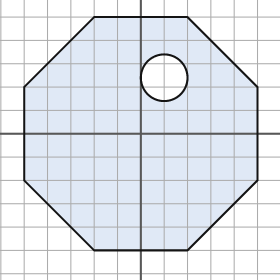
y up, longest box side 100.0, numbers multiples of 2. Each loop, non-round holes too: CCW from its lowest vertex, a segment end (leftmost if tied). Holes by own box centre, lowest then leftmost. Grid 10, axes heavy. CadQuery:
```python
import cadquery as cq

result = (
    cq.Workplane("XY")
    .moveTo(-20.0, -50.0)
    .lineTo(20.0, -50.0)
    .lineTo(50.0, -20.0)
    .lineTo(50.0, 20.0)
    .lineTo(20.0, 50.0)
    .lineTo(-20.0, 50.0)
    .lineTo(-50.0, 20.0)
    .lineTo(-50.0, -20.0)
    .close()
    .moveTo(10.0, 24.0)
    .circle(10.0)
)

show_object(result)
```